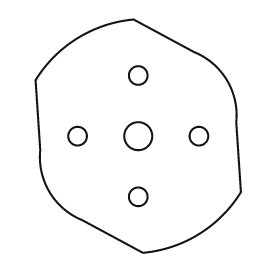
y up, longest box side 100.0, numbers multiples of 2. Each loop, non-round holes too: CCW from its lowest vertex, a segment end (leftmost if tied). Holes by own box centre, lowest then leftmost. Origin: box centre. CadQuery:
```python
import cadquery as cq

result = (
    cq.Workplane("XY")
    .moveTo(2.0, -50.0)
    .threePointArc((26.0, -42.0), (44.0, -24.0))
    .lineTo(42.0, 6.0)
    .threePointArc((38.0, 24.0), (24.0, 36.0))
    .lineTo(-2.0, 50.0)
    .threePointArc((-26.0, 42.0), (-44.0, 24.0))
    .lineTo(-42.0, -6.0)
    .threePointArc((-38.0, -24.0), (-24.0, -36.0))
    .close()
    .moveTo(0.0, -26.0)
    .circle(4.0)
    .moveTo(-26.0, 0.0)
    .circle(4.0)
    .moveTo(0.0, 0.0)
    .circle(6.0)
    .moveTo(26.0, 0.0)
    .circle(4.0)
    .moveTo(0.0, 26.0)
    .circle(4.0)
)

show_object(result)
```